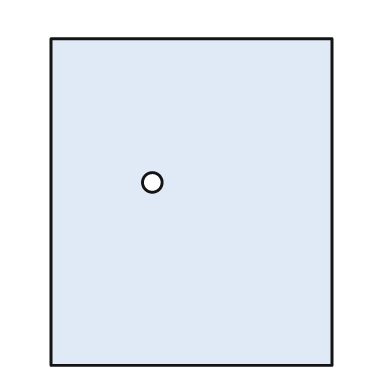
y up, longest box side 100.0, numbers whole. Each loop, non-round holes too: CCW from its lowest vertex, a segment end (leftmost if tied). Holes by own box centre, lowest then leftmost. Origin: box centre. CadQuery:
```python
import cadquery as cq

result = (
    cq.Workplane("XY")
    .moveTo(-43.0, -50.0)
    .lineTo(43.0, -50.0)
    .lineTo(43.0, 50.0)
    .lineTo(-43.0, 50.0)
    .close()
    .moveTo(-12.0, 6.0)
    .circle(3.0)
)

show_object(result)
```